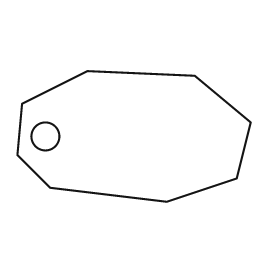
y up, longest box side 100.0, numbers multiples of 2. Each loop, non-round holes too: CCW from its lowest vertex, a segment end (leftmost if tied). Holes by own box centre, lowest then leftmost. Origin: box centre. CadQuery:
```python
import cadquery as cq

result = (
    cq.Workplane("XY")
    .moveTo(14.0, -28.0)
    .lineTo(44.0, -18.0)
    .lineTo(50.0, 6.0)
    .lineTo(26.0, 26.0)
    .lineTo(-20.0, 28.0)
    .lineTo(-48.0, 14.0)
    .lineTo(-50.0, -8.0)
    .lineTo(-36.0, -22.0)
    .close()
    .moveTo(-38.0, 0.0)
    .circle(6.0)
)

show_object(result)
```